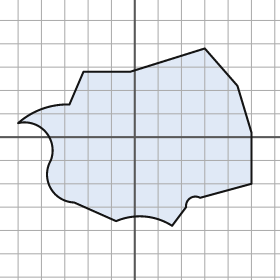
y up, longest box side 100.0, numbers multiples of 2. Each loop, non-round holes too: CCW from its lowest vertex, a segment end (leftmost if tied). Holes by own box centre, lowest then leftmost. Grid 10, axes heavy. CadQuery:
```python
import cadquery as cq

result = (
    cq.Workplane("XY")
    .moveTo(16.0, -38.0)
    .lineTo(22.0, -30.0)
    .threePointArc((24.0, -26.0), (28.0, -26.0))
    .lineTo(50.0, -20.0)
    .lineTo(50.0, 2.0)
    .lineTo(44.0, 22.0)
    .lineTo(30.0, 38.0)
    .lineTo(-2.0, 28.0)
    .lineTo(-22.0, 28.0)
    .lineTo(-28.0, 14.0)
    .threePointArc((-40.0, 12.0), (-50.0, 6.0))
    .threePointArc((-38.0, 2.0), (-36.0, -10.0))
    .threePointArc((-36.0, -22.0), (-26.0, -28.0))
    .lineTo(-8.0, -36.0)
    .threePointArc((4.0, -34.0), (16.0, -38.0))
    .close()
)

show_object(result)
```